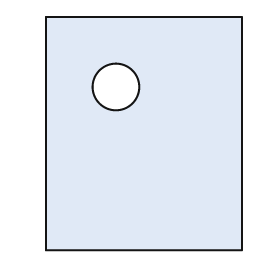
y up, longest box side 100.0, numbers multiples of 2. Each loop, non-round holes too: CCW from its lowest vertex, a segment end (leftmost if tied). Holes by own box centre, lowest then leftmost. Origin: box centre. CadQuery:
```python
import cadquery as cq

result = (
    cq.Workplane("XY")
    .moveTo(-42.0, -50.0)
    .lineTo(42.0, -50.0)
    .lineTo(42.0, 50.0)
    .lineTo(-42.0, 50.0)
    .close()
    .moveTo(-12.0, 20.0)
    .circle(10.0)
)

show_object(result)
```